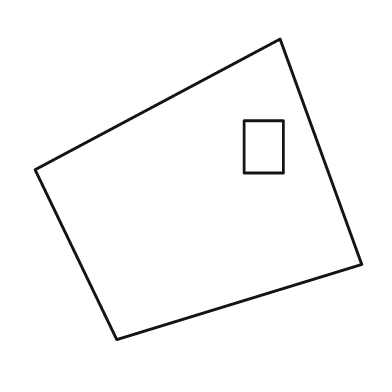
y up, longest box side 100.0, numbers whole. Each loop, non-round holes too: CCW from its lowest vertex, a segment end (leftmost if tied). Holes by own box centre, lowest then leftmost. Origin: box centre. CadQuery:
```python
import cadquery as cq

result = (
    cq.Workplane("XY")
    .moveTo(-25.0, -46.0)
    .lineTo(50.0, -23.0)
    .lineTo(25.0, 46.0)
    .lineTo(-50.0, 6.0)
    .close()
    .moveTo(14.0, 5.0)
    .lineTo(26.0, 5.0)
    .lineTo(26.0, 21.0)
    .lineTo(14.0, 21.0)
    .close()
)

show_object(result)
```